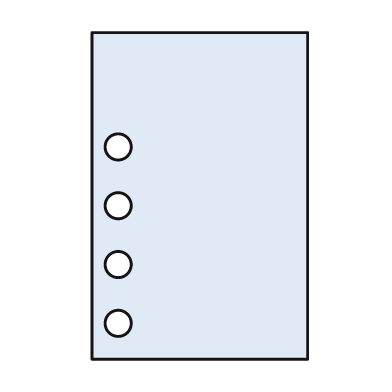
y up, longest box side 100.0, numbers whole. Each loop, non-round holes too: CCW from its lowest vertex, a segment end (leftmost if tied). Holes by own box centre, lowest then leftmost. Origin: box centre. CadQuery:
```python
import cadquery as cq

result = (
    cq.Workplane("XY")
    .moveTo(-33.0, -50.0)
    .lineTo(33.0, -50.0)
    .lineTo(33.0, 50.0)
    .lineTo(-33.0, 50.0)
    .close()
    .moveTo(-25.0, -39.0)
    .circle(4.0)
    .moveTo(-25.0, -21.0)
    .circle(4.0)
    .moveTo(-25.0, -3.0)
    .circle(4.0)
    .moveTo(-25.0, 15.0)
    .circle(4.0)
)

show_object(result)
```